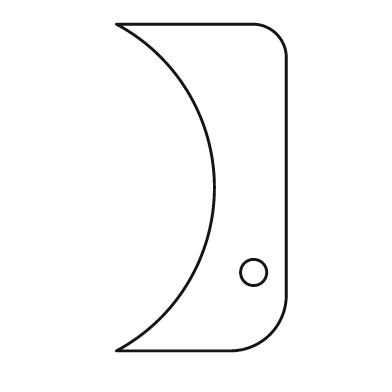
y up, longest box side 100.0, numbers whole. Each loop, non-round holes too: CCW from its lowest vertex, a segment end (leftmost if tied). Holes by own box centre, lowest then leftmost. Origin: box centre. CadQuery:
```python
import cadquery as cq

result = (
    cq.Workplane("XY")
    .moveTo(-26.0, -50.0)
    .lineTo(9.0, -50.0)
    .threePointArc((21.0, -45.0), (26.0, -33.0))
    .lineTo(26.0, 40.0)
    .threePointArc((23.0, 47.0), (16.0, 50.0))
    .lineTo(-26.0, 50.0)
    .threePointArc((4.0, 0.0), (-26.0, -50.0))
    .close()
    .moveTo(16.0, -26.0)
    .circle(4.0)
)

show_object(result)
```